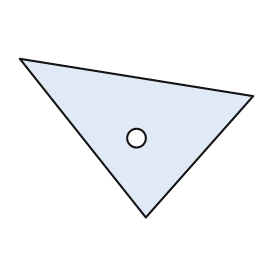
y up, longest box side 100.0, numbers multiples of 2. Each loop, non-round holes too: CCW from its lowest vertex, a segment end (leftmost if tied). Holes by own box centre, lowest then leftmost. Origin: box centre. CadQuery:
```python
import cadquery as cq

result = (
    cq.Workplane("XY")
    .moveTo(4.0, -34.0)
    .lineTo(50.0, 18.0)
    .lineTo(-50.0, 34.0)
    .close()
    .moveTo(0.0, 0.0)
    .circle(4.0)
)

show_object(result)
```